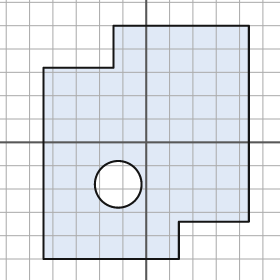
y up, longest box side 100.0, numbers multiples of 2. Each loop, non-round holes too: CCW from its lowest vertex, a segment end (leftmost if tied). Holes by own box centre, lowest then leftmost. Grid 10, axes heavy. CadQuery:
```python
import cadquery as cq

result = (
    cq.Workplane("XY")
    .moveTo(-44.0, -50.0)
    .lineTo(14.0, -50.0)
    .lineTo(14.0, -34.0)
    .lineTo(44.0, -34.0)
    .lineTo(44.0, 50.0)
    .lineTo(-14.0, 50.0)
    .lineTo(-14.0, 32.0)
    .lineTo(-44.0, 32.0)
    .close()
    .moveTo(-12.0, -18.0)
    .circle(10.0)
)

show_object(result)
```